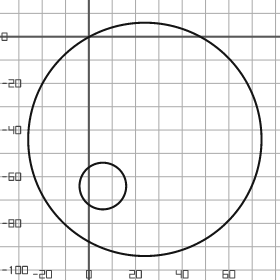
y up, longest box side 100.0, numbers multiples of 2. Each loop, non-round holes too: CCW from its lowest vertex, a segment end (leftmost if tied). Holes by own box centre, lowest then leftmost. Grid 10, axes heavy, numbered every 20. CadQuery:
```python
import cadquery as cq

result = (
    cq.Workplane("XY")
    .moveTo(24.0, -44.0)
    .circle(50.0)
    .moveTo(6.0, -64.0)
    .circle(10.0)
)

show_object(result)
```